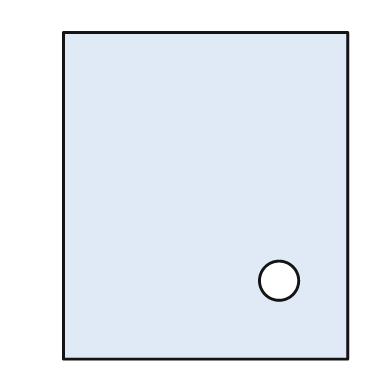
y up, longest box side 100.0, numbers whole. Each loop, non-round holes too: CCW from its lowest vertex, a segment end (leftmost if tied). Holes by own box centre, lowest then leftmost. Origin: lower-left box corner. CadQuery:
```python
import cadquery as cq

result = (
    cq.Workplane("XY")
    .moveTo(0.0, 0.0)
    .lineTo(87.0, 0.0)
    .lineTo(87.0, 100.0)
    .lineTo(0.0, 100.0)
    .close()
    .moveTo(66.0, 24.0)
    .circle(6.0)
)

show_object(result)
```